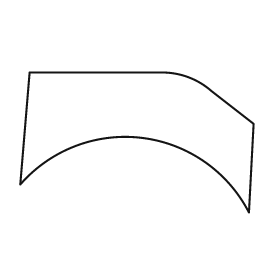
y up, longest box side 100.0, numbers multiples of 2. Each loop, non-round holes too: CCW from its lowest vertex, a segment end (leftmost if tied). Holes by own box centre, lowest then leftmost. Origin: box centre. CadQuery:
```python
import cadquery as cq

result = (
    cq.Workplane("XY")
    .moveTo(48.0, -30.0)
    .lineTo(50.0, 8.0)
    .lineTo(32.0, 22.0)
    .threePointArc((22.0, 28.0), (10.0, 30.0))
    .lineTo(-46.0, 30.0)
    .lineTo(-50.0, -18.0)
    .threePointArc((2.0, 2.0), (48.0, -30.0))
    .close()
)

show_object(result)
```